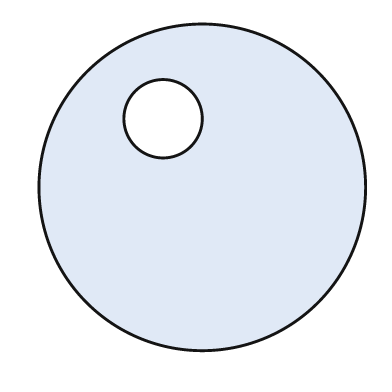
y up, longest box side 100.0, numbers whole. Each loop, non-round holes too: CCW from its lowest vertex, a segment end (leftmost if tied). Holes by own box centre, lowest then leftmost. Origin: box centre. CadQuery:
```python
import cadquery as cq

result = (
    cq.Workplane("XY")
    .moveTo(0.0, 0.0)
    .circle(50.0)
    .moveTo(-12.0, 21.0)
    .circle(12.0)
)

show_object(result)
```